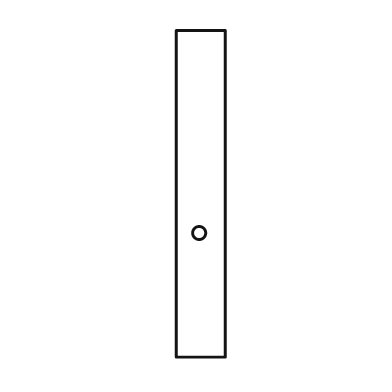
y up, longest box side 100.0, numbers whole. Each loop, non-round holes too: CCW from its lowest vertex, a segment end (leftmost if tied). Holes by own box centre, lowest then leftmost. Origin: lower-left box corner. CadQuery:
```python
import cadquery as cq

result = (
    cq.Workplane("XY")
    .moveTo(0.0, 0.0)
    .lineTo(15.0, 0.0)
    .lineTo(15.0, 100.0)
    .lineTo(0.0, 100.0)
    .close()
    .moveTo(7.0, 38.0)
    .circle(2.0)
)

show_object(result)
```